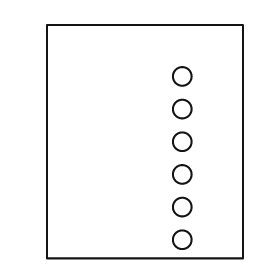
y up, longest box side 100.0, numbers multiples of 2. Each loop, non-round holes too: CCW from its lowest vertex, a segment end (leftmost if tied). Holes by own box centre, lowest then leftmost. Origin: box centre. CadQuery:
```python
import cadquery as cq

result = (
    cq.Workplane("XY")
    .moveTo(-42.0, -50.0)
    .lineTo(42.0, -50.0)
    .lineTo(42.0, 50.0)
    .lineTo(-42.0, 50.0)
    .close()
    .moveTo(16.0, -42.0)
    .circle(4.0)
    .moveTo(16.0, -28.0)
    .circle(4.0)
    .moveTo(16.0, -14.0)
    .circle(4.0)
    .moveTo(16.0, 0.0)
    .circle(4.0)
    .moveTo(16.0, 14.0)
    .circle(4.0)
    .moveTo(16.0, 28.0)
    .circle(4.0)
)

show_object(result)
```